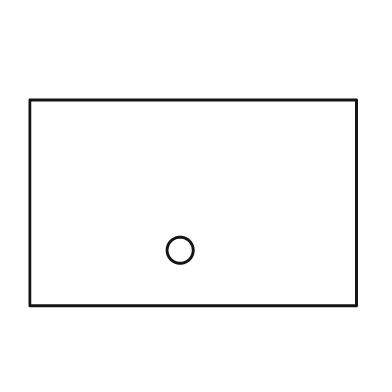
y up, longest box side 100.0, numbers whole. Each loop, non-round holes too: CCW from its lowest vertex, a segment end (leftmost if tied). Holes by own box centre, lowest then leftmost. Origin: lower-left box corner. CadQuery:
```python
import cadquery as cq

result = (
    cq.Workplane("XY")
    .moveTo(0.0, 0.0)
    .lineTo(100.0, 0.0)
    .lineTo(100.0, 63.0)
    .lineTo(0.0, 63.0)
    .close()
    .moveTo(46.0, 17.0)
    .circle(4.0)
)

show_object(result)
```